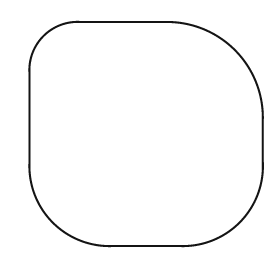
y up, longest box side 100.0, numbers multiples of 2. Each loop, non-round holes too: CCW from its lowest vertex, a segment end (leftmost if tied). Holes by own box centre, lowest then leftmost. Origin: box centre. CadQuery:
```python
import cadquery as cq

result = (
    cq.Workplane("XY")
    .moveTo(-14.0, -48.0)
    .lineTo(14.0, -48.0)
    .threePointArc((40.0, -38.0), (50.0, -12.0))
    .lineTo(50.0, 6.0)
    .threePointArc((38.0, 36.0), (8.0, 48.0))
    .lineTo(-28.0, 48.0)
    .threePointArc((-44.0, 42.0), (-50.0, 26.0))
    .lineTo(-50.0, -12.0)
    .threePointArc((-40.0, -38.0), (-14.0, -48.0))
    .close()
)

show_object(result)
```